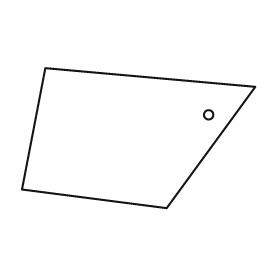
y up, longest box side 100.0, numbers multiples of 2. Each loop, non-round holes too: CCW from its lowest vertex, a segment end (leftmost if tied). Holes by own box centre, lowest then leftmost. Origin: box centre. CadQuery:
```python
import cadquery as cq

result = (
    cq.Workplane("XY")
    .moveTo(12.0, -30.0)
    .lineTo(50.0, 22.0)
    .lineTo(-40.0, 30.0)
    .lineTo(-50.0, -22.0)
    .close()
    .moveTo(30.0, 10.0)
    .circle(2.0)
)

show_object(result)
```